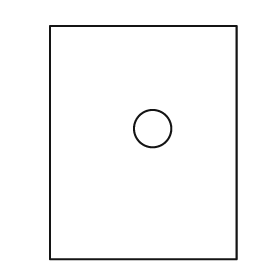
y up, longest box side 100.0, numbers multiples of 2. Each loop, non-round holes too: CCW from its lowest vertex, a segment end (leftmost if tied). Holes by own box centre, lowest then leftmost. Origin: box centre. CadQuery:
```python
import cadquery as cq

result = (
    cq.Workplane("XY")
    .moveTo(-40.0, -50.0)
    .lineTo(40.0, -50.0)
    .lineTo(40.0, 50.0)
    .lineTo(-40.0, 50.0)
    .close()
    .moveTo(4.0, 6.0)
    .circle(8.0)
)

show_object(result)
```